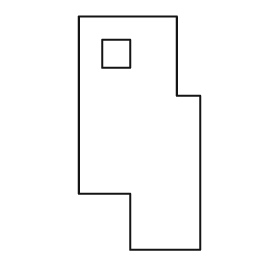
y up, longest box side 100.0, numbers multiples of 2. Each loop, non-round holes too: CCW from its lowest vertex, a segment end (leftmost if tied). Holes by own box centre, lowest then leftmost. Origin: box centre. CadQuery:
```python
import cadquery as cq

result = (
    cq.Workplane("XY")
    .moveTo(-4.0, -50.0)
    .lineTo(26.0, -50.0)
    .lineTo(26.0, 16.0)
    .lineTo(16.0, 16.0)
    .lineTo(16.0, 50.0)
    .lineTo(-26.0, 50.0)
    .lineTo(-26.0, -26.0)
    .lineTo(-4.0, -26.0)
    .close()
    .moveTo(-16.0, 28.0)
    .lineTo(-4.0, 28.0)
    .lineTo(-4.0, 40.0)
    .lineTo(-16.0, 40.0)
    .close()
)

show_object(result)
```